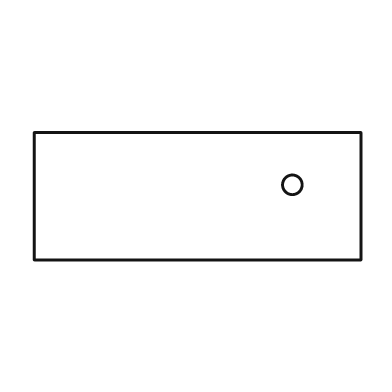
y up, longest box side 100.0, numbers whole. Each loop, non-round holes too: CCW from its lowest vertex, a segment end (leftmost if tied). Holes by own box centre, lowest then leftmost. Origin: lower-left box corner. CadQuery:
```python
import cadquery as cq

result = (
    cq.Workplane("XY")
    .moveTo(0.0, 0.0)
    .lineTo(100.0, 0.0)
    .lineTo(100.0, 39.0)
    .lineTo(0.0, 39.0)
    .close()
    .moveTo(79.0, 23.0)
    .circle(3.0)
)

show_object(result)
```